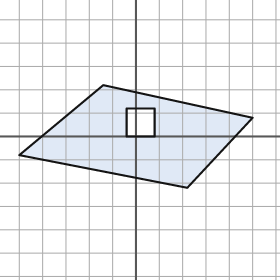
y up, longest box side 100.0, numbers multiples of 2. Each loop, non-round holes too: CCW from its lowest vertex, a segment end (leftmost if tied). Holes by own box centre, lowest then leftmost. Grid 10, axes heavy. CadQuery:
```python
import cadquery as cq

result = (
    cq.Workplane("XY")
    .moveTo(22.0, -22.0)
    .lineTo(50.0, 8.0)
    .lineTo(-14.0, 22.0)
    .lineTo(-50.0, -8.0)
    .close()
    .moveTo(-4.0, 0.0)
    .lineTo(8.0, 0.0)
    .lineTo(8.0, 12.0)
    .lineTo(-4.0, 12.0)
    .close()
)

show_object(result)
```